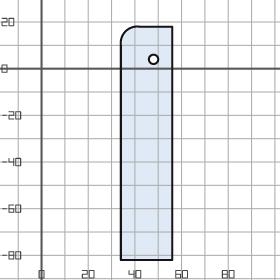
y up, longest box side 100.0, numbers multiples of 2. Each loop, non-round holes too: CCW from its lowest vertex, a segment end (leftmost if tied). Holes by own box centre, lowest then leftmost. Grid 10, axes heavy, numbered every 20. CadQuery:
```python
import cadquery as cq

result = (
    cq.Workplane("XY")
    .moveTo(34.0, -82.0)
    .lineTo(56.0, -82.0)
    .lineTo(56.0, 18.0)
    .lineTo(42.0, 18.0)
    .threePointArc((36.0, 16.0), (34.0, 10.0))
    .close()
    .moveTo(48.0, 4.0)
    .circle(2.0)
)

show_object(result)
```